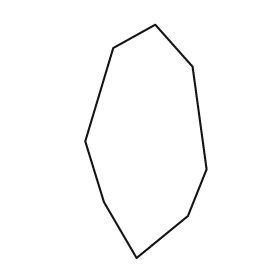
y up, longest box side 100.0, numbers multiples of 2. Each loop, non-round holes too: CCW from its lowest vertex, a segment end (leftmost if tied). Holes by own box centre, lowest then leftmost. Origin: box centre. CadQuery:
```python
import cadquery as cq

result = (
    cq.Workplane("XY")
    .moveTo(-4.0, -50.0)
    .lineTo(18.0, -32.0)
    .lineTo(26.0, -12.0)
    .lineTo(20.0, 32.0)
    .lineTo(4.0, 50.0)
    .lineTo(-14.0, 40.0)
    .lineTo(-26.0, 0.0)
    .lineTo(-18.0, -26.0)
    .close()
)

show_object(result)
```